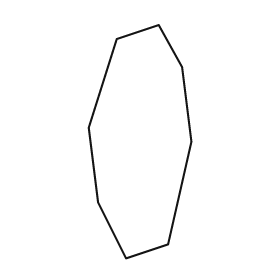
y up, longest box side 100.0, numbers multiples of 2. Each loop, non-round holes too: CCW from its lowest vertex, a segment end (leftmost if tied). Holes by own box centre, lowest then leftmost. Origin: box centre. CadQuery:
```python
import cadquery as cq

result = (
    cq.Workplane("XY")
    .moveTo(-6.0, -50.0)
    .lineTo(12.0, -44.0)
    .lineTo(22.0, 0.0)
    .lineTo(18.0, 32.0)
    .lineTo(8.0, 50.0)
    .lineTo(-10.0, 44.0)
    .lineTo(-22.0, 6.0)
    .lineTo(-18.0, -26.0)
    .close()
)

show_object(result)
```